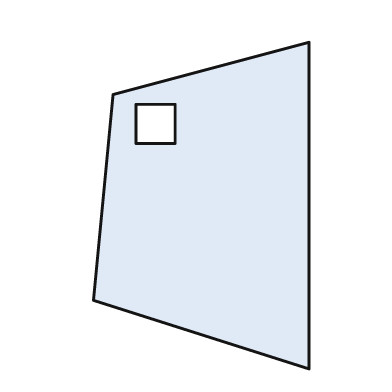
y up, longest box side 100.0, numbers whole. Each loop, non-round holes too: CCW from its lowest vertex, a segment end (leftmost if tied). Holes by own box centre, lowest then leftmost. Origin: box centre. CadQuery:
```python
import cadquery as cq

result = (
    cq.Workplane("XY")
    .moveTo(33.0, -50.0)
    .lineTo(33.0, 50.0)
    .lineTo(-27.0, 34.0)
    .lineTo(-33.0, -29.0)
    .close()
    .moveTo(-20.0, 19.0)
    .lineTo(-8.0, 19.0)
    .lineTo(-8.0, 31.0)
    .lineTo(-20.0, 31.0)
    .close()
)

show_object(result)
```